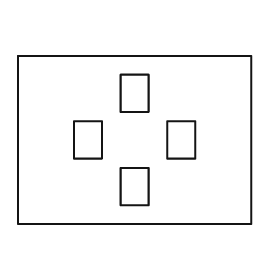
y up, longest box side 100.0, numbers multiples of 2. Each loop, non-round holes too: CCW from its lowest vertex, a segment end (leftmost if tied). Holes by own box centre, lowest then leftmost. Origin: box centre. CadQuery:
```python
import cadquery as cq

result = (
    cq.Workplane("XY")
    .moveTo(-50.0, -36.0)
    .lineTo(50.0, -36.0)
    .lineTo(50.0, 36.0)
    .lineTo(-50.0, 36.0)
    .close()
    .moveTo(-6.0, -28.0)
    .lineTo(6.0, -28.0)
    .lineTo(6.0, -12.0)
    .lineTo(-6.0, -12.0)
    .close()
    .moveTo(-26.0, -8.0)
    .lineTo(-14.0, -8.0)
    .lineTo(-14.0, 8.0)
    .lineTo(-26.0, 8.0)
    .close()
    .moveTo(14.0, -8.0)
    .lineTo(26.0, -8.0)
    .lineTo(26.0, 8.0)
    .lineTo(14.0, 8.0)
    .close()
    .moveTo(-6.0, 12.0)
    .lineTo(6.0, 12.0)
    .lineTo(6.0, 28.0)
    .lineTo(-6.0, 28.0)
    .close()
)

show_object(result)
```